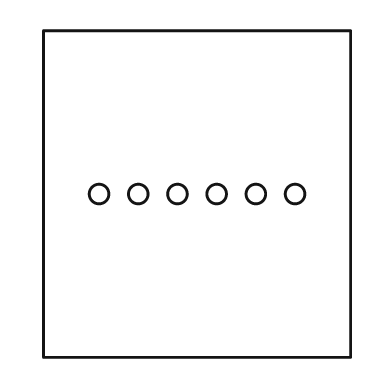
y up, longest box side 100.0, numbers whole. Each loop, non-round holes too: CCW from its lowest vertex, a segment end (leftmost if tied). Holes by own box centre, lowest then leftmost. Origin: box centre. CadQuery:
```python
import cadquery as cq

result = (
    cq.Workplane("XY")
    .moveTo(-47.0, -50.0)
    .lineTo(47.0, -50.0)
    .lineTo(47.0, 50.0)
    .lineTo(-47.0, 50.0)
    .close()
    .moveTo(-30.0, 0.0)
    .circle(3.0)
    .moveTo(-18.0, 0.0)
    .circle(3.0)
    .moveTo(-6.0, 0.0)
    .circle(3.0)
    .moveTo(6.0, 0.0)
    .circle(3.0)
    .moveTo(18.0, 0.0)
    .circle(3.0)
    .moveTo(30.0, 0.0)
    .circle(3.0)
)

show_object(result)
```